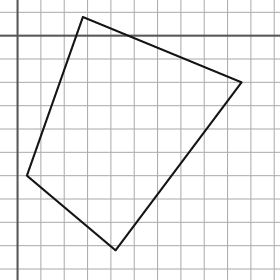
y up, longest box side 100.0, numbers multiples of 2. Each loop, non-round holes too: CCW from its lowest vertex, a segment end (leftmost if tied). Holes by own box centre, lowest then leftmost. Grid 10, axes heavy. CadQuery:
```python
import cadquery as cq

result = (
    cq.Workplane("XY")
    .moveTo(42.0, -92.0)
    .lineTo(96.0, -20.0)
    .lineTo(28.0, 8.0)
    .lineTo(4.0, -60.0)
    .close()
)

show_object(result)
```